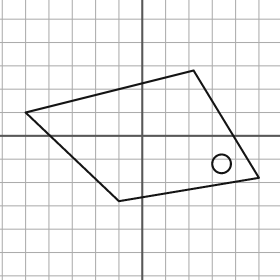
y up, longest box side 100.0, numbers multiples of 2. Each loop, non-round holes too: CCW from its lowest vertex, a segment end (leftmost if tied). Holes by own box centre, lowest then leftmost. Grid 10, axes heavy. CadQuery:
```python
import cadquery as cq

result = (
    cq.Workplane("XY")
    .moveTo(-10.0, -28.0)
    .lineTo(50.0, -18.0)
    .lineTo(22.0, 28.0)
    .lineTo(-50.0, 10.0)
    .close()
    .moveTo(34.0, -12.0)
    .circle(4.0)
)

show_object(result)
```